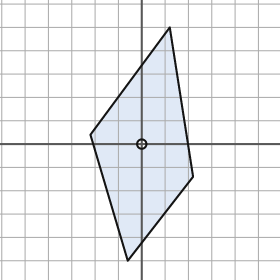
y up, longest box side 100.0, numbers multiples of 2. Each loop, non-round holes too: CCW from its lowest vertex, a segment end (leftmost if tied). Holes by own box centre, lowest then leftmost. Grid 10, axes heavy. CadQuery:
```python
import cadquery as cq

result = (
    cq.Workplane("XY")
    .moveTo(-6.0, -50.0)
    .lineTo(22.0, -14.0)
    .lineTo(12.0, 50.0)
    .lineTo(-22.0, 4.0)
    .close()
    .moveTo(0.0, 0.0)
    .circle(2.0)
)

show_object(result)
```